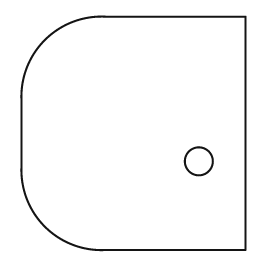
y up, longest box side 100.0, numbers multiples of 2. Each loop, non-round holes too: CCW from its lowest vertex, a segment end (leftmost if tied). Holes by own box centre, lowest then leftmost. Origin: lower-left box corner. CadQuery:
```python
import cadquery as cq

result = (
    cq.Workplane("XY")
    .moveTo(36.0, 0.0)
    .lineTo(96.0, 0.0)
    .lineTo(96.0, 100.0)
    .lineTo(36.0, 100.0)
    .threePointArc((10.0, 90.0), (0.0, 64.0))
    .lineTo(0.0, 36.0)
    .threePointArc((10.0, 10.0), (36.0, 0.0))
    .close()
    .moveTo(76.0, 38.0)
    .circle(6.0)
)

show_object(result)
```